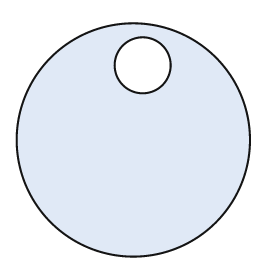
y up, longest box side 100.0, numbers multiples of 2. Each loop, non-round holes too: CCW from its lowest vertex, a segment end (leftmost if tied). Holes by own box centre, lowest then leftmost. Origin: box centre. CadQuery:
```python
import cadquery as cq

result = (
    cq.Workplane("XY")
    .moveTo(0.0, 0.0)
    .circle(50.0)
    .moveTo(4.0, 32.0)
    .circle(12.0)
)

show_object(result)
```